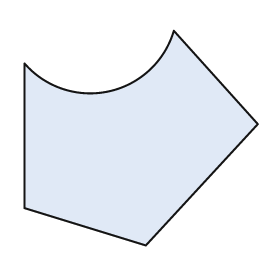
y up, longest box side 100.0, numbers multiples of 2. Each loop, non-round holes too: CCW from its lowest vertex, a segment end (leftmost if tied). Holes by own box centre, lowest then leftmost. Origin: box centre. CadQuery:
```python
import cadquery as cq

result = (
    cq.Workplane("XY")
    .moveTo(2.0, -46.0)
    .lineTo(50.0, 6.0)
    .lineTo(14.0, 46.0)
    .threePointArc((-14.0, 20.0), (-50.0, 32.0))
    .lineTo(-50.0, -30.0)
    .close()
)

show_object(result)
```